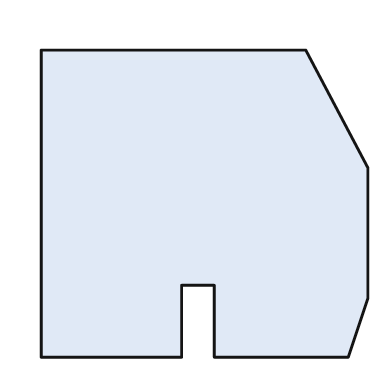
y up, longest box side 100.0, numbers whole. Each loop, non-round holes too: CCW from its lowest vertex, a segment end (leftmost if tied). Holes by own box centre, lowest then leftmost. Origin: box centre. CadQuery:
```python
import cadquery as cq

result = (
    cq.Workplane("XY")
    .moveTo(-50.0, -47.0)
    .lineTo(-7.0, -47.0)
    .lineTo(-7.0, -25.0)
    .lineTo(3.0, -25.0)
    .lineTo(3.0, -47.0)
    .lineTo(44.0, -47.0)
    .lineTo(50.0, -29.0)
    .lineTo(50.0, 11.0)
    .lineTo(31.0, 47.0)
    .lineTo(-50.0, 47.0)
    .close()
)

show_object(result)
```